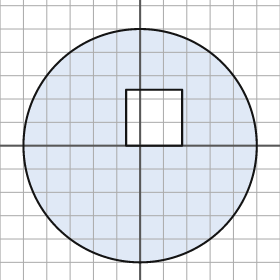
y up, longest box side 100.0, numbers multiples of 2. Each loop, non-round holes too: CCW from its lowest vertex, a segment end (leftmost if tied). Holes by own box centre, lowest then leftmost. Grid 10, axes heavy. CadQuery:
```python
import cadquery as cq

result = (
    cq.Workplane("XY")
    .moveTo(0.0, 0.0)
    .circle(50.0)
    .moveTo(-6.0, 0.0)
    .lineTo(18.0, 0.0)
    .lineTo(18.0, 24.0)
    .lineTo(-6.0, 24.0)
    .close()
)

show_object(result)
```